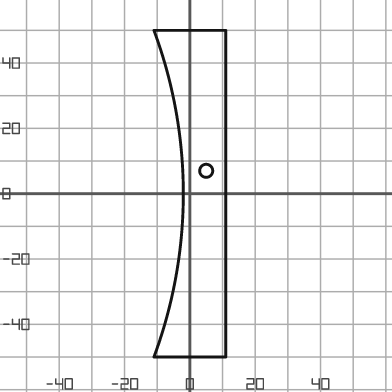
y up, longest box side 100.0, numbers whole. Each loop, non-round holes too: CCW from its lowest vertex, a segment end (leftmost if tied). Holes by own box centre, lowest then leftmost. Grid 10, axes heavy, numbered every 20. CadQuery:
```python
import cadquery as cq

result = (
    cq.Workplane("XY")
    .moveTo(-11.0, -50.0)
    .lineTo(11.0, -50.0)
    .lineTo(11.0, 50.0)
    .lineTo(-11.0, 50.0)
    .threePointArc((-2.0, 0.0), (-11.0, -50.0))
    .close()
    .moveTo(5.0, 7.0)
    .circle(2.0)
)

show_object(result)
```